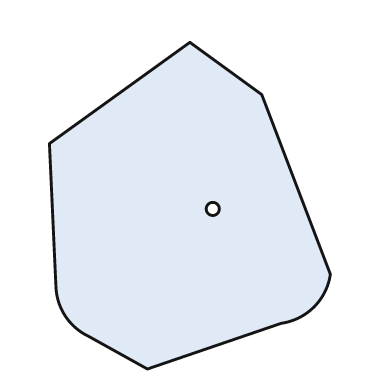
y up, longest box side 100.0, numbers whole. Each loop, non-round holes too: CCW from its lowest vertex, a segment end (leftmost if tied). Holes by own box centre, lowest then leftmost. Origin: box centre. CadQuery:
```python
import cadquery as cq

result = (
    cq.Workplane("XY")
    .moveTo(-13.0, -50.0)
    .lineTo(28.0, -36.0)
    .threePointArc((38.0, -31.0), (43.0, -21.0))
    .lineTo(22.0, 34.0)
    .lineTo(0.0, 50.0)
    .lineTo(-43.0, 19.0)
    .lineTo(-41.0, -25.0)
    .threePointArc((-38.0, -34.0), (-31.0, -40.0))
    .close()
    .moveTo(7.0, -1.0)
    .circle(2.0)
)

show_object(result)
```